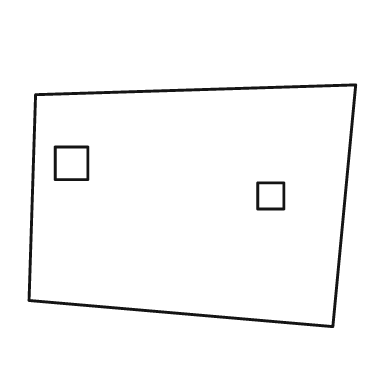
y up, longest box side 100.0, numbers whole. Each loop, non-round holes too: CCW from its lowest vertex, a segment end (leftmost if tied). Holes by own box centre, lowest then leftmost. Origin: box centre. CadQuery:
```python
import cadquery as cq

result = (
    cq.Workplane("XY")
    .moveTo(43.0, -37.0)
    .lineTo(50.0, 37.0)
    .lineTo(-48.0, 34.0)
    .lineTo(-50.0, -29.0)
    .close()
    .moveTo(20.0, -1.0)
    .lineTo(28.0, -1.0)
    .lineTo(28.0, 7.0)
    .lineTo(20.0, 7.0)
    .close()
    .moveTo(-42.0, 8.0)
    .lineTo(-32.0, 8.0)
    .lineTo(-32.0, 18.0)
    .lineTo(-42.0, 18.0)
    .close()
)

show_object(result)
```